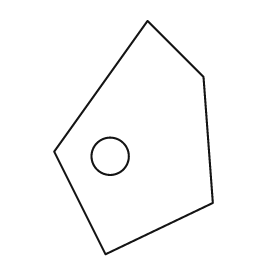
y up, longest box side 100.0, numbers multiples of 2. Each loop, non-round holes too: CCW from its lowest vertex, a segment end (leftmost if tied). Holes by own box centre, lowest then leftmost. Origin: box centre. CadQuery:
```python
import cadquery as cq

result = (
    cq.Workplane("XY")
    .moveTo(-12.0, -50.0)
    .lineTo(34.0, -28.0)
    .lineTo(30.0, 26.0)
    .lineTo(6.0, 50.0)
    .lineTo(-34.0, -6.0)
    .close()
    .moveTo(-10.0, -8.0)
    .circle(8.0)
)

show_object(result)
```